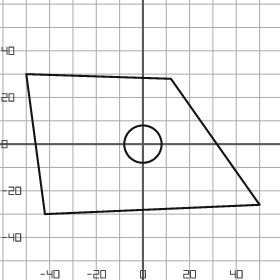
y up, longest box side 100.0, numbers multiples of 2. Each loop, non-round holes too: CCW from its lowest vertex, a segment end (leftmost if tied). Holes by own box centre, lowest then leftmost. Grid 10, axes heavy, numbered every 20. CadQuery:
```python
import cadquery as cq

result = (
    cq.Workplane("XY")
    .moveTo(-42.0, -30.0)
    .lineTo(50.0, -26.0)
    .lineTo(12.0, 28.0)
    .lineTo(-50.0, 30.0)
    .close()
    .moveTo(0.0, 0.0)
    .circle(8.0)
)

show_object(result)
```